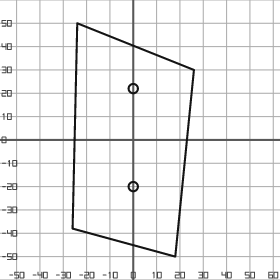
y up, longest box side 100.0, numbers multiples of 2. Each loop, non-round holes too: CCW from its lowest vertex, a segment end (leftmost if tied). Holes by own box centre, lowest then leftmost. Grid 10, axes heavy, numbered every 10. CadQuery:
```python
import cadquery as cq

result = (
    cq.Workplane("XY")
    .moveTo(18.0, -50.0)
    .lineTo(26.0, 30.0)
    .lineTo(-24.0, 50.0)
    .lineTo(-26.0, -38.0)
    .close()
    .moveTo(0.0, -20.0)
    .circle(2.0)
    .moveTo(0.0, 22.0)
    .circle(2.0)
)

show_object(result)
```